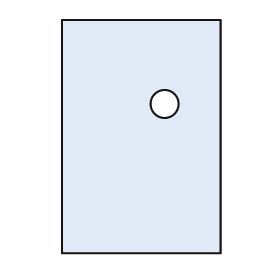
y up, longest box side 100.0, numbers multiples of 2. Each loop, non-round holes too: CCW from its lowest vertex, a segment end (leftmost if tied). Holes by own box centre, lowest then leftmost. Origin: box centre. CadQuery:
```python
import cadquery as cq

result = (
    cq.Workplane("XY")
    .moveTo(-34.0, -50.0)
    .lineTo(34.0, -50.0)
    .lineTo(34.0, 50.0)
    .lineTo(-34.0, 50.0)
    .close()
    .moveTo(10.0, 14.0)
    .circle(6.0)
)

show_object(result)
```